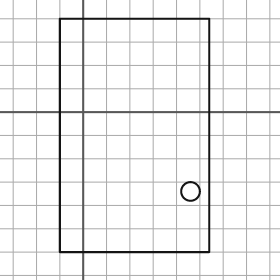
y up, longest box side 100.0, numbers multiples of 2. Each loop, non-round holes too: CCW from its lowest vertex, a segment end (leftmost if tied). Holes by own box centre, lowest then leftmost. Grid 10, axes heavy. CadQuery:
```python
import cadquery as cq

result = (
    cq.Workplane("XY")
    .moveTo(-10.0, -60.0)
    .lineTo(54.0, -60.0)
    .lineTo(54.0, 40.0)
    .lineTo(-10.0, 40.0)
    .close()
    .moveTo(46.0, -34.0)
    .circle(4.0)
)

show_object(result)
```